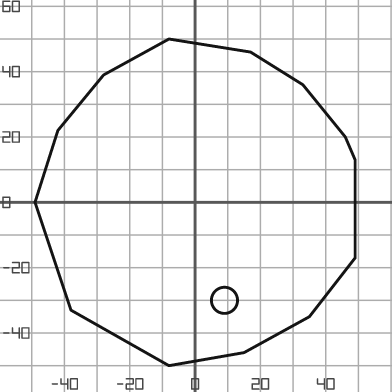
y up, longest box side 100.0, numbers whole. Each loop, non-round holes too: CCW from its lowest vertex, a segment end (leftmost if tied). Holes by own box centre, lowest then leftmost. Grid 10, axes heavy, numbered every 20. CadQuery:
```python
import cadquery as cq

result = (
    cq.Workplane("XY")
    .moveTo(-8.0, -50.0)
    .lineTo(15.0, -46.0)
    .lineTo(35.0, -35.0)
    .lineTo(49.0, -17.0)
    .lineTo(49.0, 13.0)
    .lineTo(46.0, 20.0)
    .lineTo(33.0, 36.0)
    .lineTo(17.0, 46.0)
    .lineTo(-8.0, 50.0)
    .lineTo(-28.0, 39.0)
    .lineTo(-42.0, 22.0)
    .lineTo(-49.0, 0.0)
    .lineTo(-38.0, -33.0)
    .close()
    .moveTo(9.0, -30.0)
    .circle(4.0)
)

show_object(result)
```